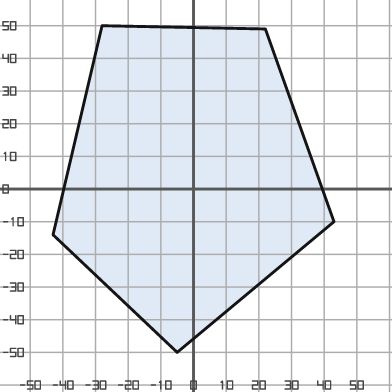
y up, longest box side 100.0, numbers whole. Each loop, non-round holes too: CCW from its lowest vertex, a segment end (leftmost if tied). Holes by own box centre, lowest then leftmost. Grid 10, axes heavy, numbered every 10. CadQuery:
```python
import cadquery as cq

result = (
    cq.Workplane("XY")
    .moveTo(-5.0, -50.0)
    .lineTo(43.0, -10.0)
    .lineTo(22.0, 49.0)
    .lineTo(-28.0, 50.0)
    .lineTo(-43.0, -14.0)
    .close()
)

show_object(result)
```